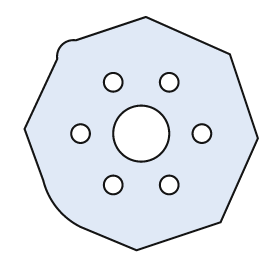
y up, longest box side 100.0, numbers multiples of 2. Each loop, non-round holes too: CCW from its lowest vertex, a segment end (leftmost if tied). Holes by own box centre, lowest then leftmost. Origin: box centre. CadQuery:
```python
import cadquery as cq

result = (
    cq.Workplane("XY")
    .moveTo(-2.0, -50.0)
    .lineTo(34.0, -38.0)
    .lineTo(50.0, -2.0)
    .lineTo(38.0, 34.0)
    .lineTo(2.0, 50.0)
    .lineTo(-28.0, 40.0)
    .threePointArc((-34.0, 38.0), (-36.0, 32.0))
    .lineTo(-50.0, 2.0)
    .lineTo(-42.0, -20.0)
    .threePointArc((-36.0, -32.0), (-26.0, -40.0))
    .close()
    .moveTo(-12.0, -22.0)
    .circle(4.0)
    .moveTo(12.0, -22.0)
    .circle(4.0)
    .moveTo(-26.0, 0.0)
    .circle(4.0)
    .moveTo(0.0, 0.0)
    .circle(12.0)
    .moveTo(26.0, 0.0)
    .circle(4.0)
    .moveTo(-12.0, 22.0)
    .circle(4.0)
    .moveTo(12.0, 22.0)
    .circle(4.0)
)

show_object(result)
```